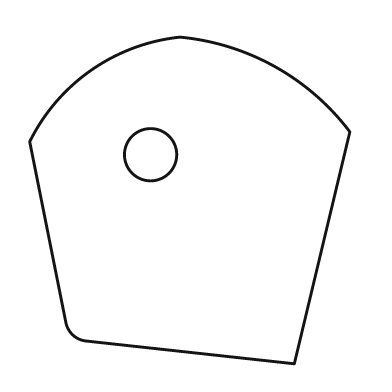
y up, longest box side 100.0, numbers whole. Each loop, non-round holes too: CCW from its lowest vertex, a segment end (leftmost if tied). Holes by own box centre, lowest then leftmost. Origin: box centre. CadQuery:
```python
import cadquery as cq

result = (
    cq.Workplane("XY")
    .moveTo(32.0, -50.0)
    .lineTo(49.0, 21.0)
    .threePointArc((26.0, 41.0), (-3.0, 50.0))
    .threePointArc((-30.0, 40.0), (-49.0, 18.0))
    .lineTo(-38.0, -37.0)
    .threePointArc((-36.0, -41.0), (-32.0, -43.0))
    .close()
    .moveTo(-12.0, 14.0)
    .circle(8.0)
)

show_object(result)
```